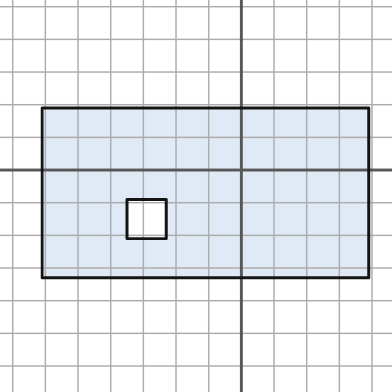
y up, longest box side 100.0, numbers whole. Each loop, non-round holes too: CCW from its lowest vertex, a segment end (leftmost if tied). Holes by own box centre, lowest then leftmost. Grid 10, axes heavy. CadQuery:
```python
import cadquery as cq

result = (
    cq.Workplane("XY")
    .moveTo(-61.0, -33.0)
    .lineTo(39.0, -33.0)
    .lineTo(39.0, 19.0)
    .lineTo(-61.0, 19.0)
    .close()
    .moveTo(-35.0, -21.0)
    .lineTo(-23.0, -21.0)
    .lineTo(-23.0, -9.0)
    .lineTo(-35.0, -9.0)
    .close()
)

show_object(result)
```